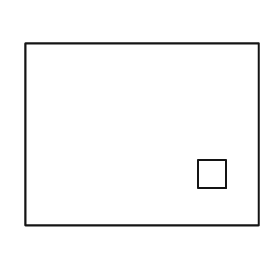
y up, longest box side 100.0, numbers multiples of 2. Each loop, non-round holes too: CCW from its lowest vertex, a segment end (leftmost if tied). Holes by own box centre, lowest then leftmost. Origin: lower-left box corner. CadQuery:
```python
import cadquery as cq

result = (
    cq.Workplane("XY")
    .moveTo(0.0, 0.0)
    .lineTo(100.0, 0.0)
    .lineTo(100.0, 78.0)
    .lineTo(0.0, 78.0)
    .close()
    .moveTo(74.0, 16.0)
    .lineTo(86.0, 16.0)
    .lineTo(86.0, 28.0)
    .lineTo(74.0, 28.0)
    .close()
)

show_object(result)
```